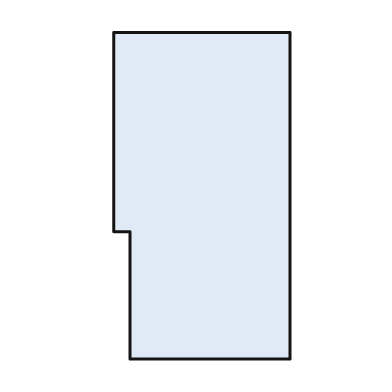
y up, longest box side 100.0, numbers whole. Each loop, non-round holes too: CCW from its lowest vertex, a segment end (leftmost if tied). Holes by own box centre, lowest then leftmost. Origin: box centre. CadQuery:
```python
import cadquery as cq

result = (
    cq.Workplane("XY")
    .moveTo(-22.0, -50.0)
    .lineTo(27.0, -50.0)
    .lineTo(27.0, 50.0)
    .lineTo(-27.0, 50.0)
    .lineTo(-27.0, -11.0)
    .lineTo(-22.0, -11.0)
    .close()
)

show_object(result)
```